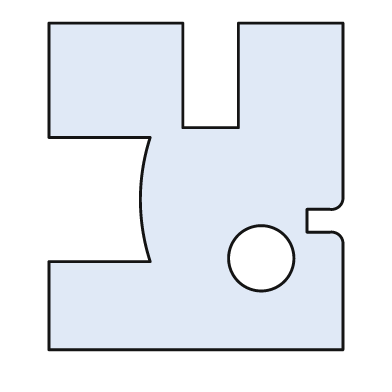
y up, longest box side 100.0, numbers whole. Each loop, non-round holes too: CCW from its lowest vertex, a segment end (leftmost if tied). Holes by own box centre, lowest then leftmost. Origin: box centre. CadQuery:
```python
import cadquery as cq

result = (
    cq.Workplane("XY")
    .moveTo(-45.0, -50.0)
    .lineTo(45.0, -50.0)
    .lineTo(45.0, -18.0)
    .threePointArc((44.0, -15.0), (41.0, -14.0))
    .lineTo(34.0, -14.0)
    .lineTo(34.0, -7.0)
    .lineTo(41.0, -7.0)
    .threePointArc((44.0, -6.0), (45.0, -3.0))
    .lineTo(45.0, 50.0)
    .lineTo(13.0, 50.0)
    .lineTo(13.0, 18.0)
    .lineTo(-4.0, 18.0)
    .lineTo(-4.0, 50.0)
    .lineTo(-45.0, 50.0)
    .lineTo(-45.0, 15.0)
    .lineTo(-14.0, 15.0)
    .threePointArc((-17.0, -4.0), (-14.0, -23.0))
    .lineTo(-45.0, -23.0)
    .close()
    .moveTo(20.0, -22.0)
    .circle(10.0)
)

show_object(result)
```